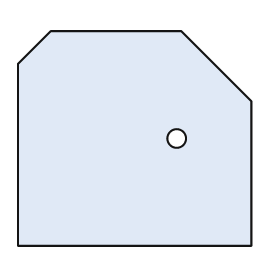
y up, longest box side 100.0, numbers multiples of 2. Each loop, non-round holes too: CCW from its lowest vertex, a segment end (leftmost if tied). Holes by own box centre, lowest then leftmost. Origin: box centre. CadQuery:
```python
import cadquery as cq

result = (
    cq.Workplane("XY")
    .moveTo(-50.0, -46.0)
    .lineTo(50.0, -46.0)
    .lineTo(50.0, 16.0)
    .lineTo(20.0, 46.0)
    .lineTo(-36.0, 46.0)
    .lineTo(-50.0, 32.0)
    .close()
    .moveTo(18.0, 0.0)
    .circle(4.0)
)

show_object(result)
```